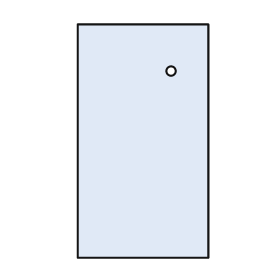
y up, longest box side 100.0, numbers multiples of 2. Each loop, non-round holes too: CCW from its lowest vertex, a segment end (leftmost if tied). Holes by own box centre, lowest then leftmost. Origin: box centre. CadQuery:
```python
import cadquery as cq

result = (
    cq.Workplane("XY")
    .moveTo(-28.0, -50.0)
    .lineTo(28.0, -50.0)
    .lineTo(28.0, 50.0)
    .lineTo(-28.0, 50.0)
    .close()
    .moveTo(12.0, 30.0)
    .circle(2.0)
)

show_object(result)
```